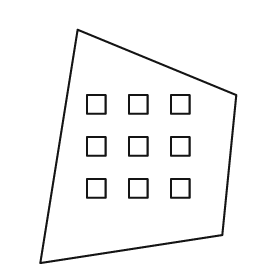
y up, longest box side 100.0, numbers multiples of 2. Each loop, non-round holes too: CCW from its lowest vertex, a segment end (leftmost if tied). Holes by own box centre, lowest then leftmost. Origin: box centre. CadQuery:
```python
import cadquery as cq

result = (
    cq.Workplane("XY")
    .moveTo(-42.0, -50.0)
    .lineTo(36.0, -38.0)
    .lineTo(42.0, 22.0)
    .lineTo(-26.0, 50.0)
    .close()
    .moveTo(-22.0, -22.0)
    .lineTo(-14.0, -22.0)
    .lineTo(-14.0, -14.0)
    .lineTo(-22.0, -14.0)
    .close()
    .moveTo(-4.0, -22.0)
    .lineTo(4.0, -22.0)
    .lineTo(4.0, -14.0)
    .lineTo(-4.0, -14.0)
    .close()
    .moveTo(14.0, -22.0)
    .lineTo(22.0, -22.0)
    .lineTo(22.0, -14.0)
    .lineTo(14.0, -14.0)
    .close()
    .moveTo(-22.0, -4.0)
    .lineTo(-14.0, -4.0)
    .lineTo(-14.0, 4.0)
    .lineTo(-22.0, 4.0)
    .close()
    .moveTo(-4.0, -4.0)
    .lineTo(4.0, -4.0)
    .lineTo(4.0, 4.0)
    .lineTo(-4.0, 4.0)
    .close()
    .moveTo(14.0, -4.0)
    .lineTo(22.0, -4.0)
    .lineTo(22.0, 4.0)
    .lineTo(14.0, 4.0)
    .close()
    .moveTo(-22.0, 14.0)
    .lineTo(-14.0, 14.0)
    .lineTo(-14.0, 22.0)
    .lineTo(-22.0, 22.0)
    .close()
    .moveTo(-4.0, 14.0)
    .lineTo(4.0, 14.0)
    .lineTo(4.0, 22.0)
    .lineTo(-4.0, 22.0)
    .close()
    .moveTo(14.0, 14.0)
    .lineTo(22.0, 14.0)
    .lineTo(22.0, 22.0)
    .lineTo(14.0, 22.0)
    .close()
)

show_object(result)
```